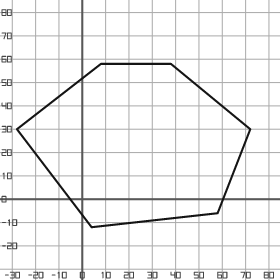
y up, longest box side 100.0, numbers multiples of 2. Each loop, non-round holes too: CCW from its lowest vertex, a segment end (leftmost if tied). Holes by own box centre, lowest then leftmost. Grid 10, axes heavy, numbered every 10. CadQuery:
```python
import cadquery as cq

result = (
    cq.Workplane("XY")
    .moveTo(4.0, -12.0)
    .lineTo(58.0, -6.0)
    .lineTo(72.0, 30.0)
    .lineTo(38.0, 58.0)
    .lineTo(8.0, 58.0)
    .lineTo(-28.0, 30.0)
    .close()
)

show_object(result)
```